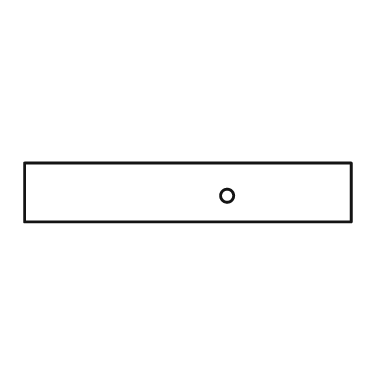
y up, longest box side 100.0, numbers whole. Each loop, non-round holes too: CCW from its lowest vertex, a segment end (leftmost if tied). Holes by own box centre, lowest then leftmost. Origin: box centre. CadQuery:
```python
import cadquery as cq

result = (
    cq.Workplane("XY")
    .moveTo(-50.0, -9.0)
    .lineTo(50.0, -9.0)
    .lineTo(50.0, 9.0)
    .lineTo(-50.0, 9.0)
    .close()
    .moveTo(12.0, -1.0)
    .circle(2.0)
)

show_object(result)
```